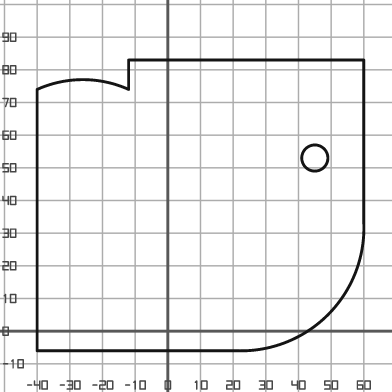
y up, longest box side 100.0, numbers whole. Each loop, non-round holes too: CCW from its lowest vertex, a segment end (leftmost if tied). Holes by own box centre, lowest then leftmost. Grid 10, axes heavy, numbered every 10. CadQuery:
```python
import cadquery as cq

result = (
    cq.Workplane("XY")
    .moveTo(-40.0, -6.0)
    .lineTo(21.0, -6.0)
    .threePointArc((49.0, 5.0), (60.0, 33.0))
    .lineTo(60.0, 83.0)
    .lineTo(-12.0, 83.0)
    .lineTo(-12.0, 74.0)
    .threePointArc((-26.0, 77.0), (-40.0, 74.0))
    .close()
    .moveTo(45.0, 53.0)
    .circle(4.0)
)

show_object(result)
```